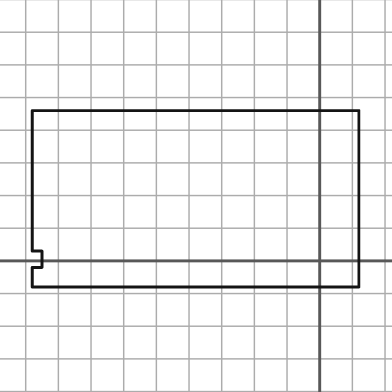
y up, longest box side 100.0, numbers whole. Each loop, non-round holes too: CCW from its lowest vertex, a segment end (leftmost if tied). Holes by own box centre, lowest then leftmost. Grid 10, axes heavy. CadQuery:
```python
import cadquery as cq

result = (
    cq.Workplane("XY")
    .moveTo(-88.0, -8.0)
    .lineTo(12.0, -8.0)
    .lineTo(12.0, 46.0)
    .lineTo(-88.0, 46.0)
    .lineTo(-88.0, 3.0)
    .lineTo(-85.0, 3.0)
    .lineTo(-85.0, -2.0)
    .lineTo(-88.0, -2.0)
    .close()
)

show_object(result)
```